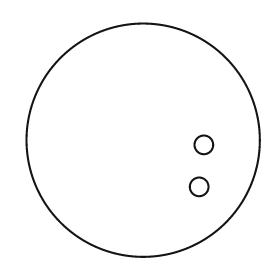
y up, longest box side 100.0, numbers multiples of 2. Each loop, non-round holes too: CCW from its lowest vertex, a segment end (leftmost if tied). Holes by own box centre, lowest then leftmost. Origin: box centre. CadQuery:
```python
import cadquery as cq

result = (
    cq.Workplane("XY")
    .moveTo(0.0, 0.0)
    .circle(50.0)
    .moveTo(24.0, -20.0)
    .circle(4.0)
    .moveTo(26.0, -2.0)
    .circle(4.0)
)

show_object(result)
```